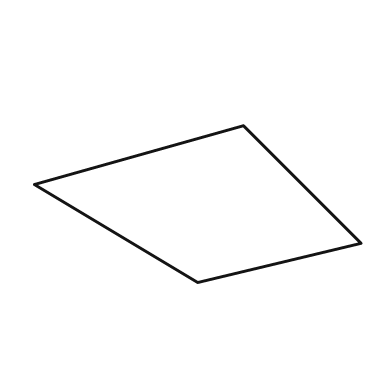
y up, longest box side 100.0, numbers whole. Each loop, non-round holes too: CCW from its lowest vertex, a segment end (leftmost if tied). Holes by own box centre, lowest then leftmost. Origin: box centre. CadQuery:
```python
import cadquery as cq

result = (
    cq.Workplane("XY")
    .moveTo(0.0, -24.0)
    .lineTo(50.0, -12.0)
    .lineTo(14.0, 24.0)
    .lineTo(-50.0, 6.0)
    .close()
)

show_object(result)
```